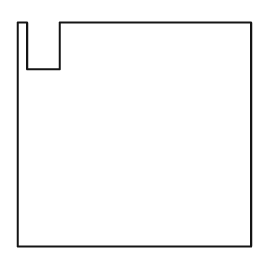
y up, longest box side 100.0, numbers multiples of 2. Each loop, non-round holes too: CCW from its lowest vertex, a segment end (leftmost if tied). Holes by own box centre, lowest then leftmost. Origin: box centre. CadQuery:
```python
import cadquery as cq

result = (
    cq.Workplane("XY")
    .moveTo(-50.0, -48.0)
    .lineTo(50.0, -48.0)
    .lineTo(50.0, 48.0)
    .lineTo(-32.0, 48.0)
    .lineTo(-32.0, 28.0)
    .lineTo(-46.0, 28.0)
    .lineTo(-46.0, 48.0)
    .lineTo(-50.0, 48.0)
    .close()
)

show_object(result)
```